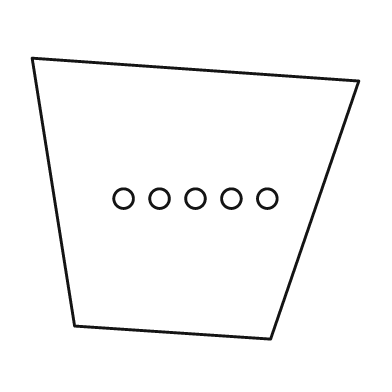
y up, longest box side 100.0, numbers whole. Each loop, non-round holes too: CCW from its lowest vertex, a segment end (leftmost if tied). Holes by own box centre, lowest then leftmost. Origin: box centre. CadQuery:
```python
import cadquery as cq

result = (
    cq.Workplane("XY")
    .moveTo(23.0, -43.0)
    .lineTo(50.0, 36.0)
    .lineTo(-50.0, 43.0)
    .lineTo(-37.0, -39.0)
    .close()
    .moveTo(-22.0, 0.0)
    .circle(3.0)
    .moveTo(-11.0, 0.0)
    .circle(3.0)
    .moveTo(0.0, 0.0)
    .circle(3.0)
    .moveTo(11.0, 0.0)
    .circle(3.0)
    .moveTo(22.0, 0.0)
    .circle(3.0)
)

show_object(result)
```